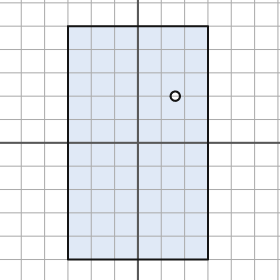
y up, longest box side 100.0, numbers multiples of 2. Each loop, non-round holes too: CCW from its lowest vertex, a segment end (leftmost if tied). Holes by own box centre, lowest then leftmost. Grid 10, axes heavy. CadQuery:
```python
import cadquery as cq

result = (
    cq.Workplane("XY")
    .moveTo(-30.0, -50.0)
    .lineTo(30.0, -50.0)
    .lineTo(30.0, 50.0)
    .lineTo(-30.0, 50.0)
    .close()
    .moveTo(16.0, 20.0)
    .circle(2.0)
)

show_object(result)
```